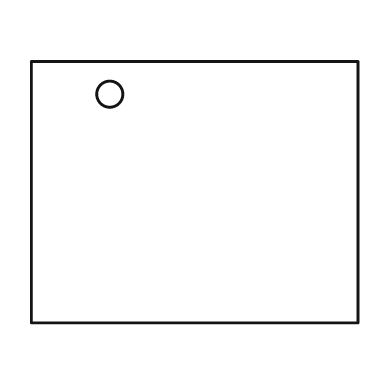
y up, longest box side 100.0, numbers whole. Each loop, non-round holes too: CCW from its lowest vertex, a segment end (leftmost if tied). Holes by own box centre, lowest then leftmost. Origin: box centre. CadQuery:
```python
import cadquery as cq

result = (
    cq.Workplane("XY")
    .moveTo(-50.0, -40.0)
    .lineTo(50.0, -40.0)
    .lineTo(50.0, 40.0)
    .lineTo(-50.0, 40.0)
    .close()
    .moveTo(-26.0, 30.0)
    .circle(4.0)
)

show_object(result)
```